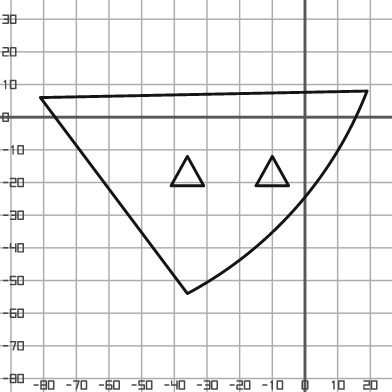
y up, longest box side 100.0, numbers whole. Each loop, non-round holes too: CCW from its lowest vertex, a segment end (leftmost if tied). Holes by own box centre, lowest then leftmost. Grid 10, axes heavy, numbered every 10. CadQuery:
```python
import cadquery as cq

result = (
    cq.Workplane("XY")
    .moveTo(-36.0, -54.0)
    .threePointArc((-3.0, -28.0), (19.0, 8.0))
    .lineTo(-81.0, 6.0)
    .close()
    .moveTo(-41.0, -21.0)
    .lineTo(-31.0, -21.0)
    .lineTo(-36.0, -12.0)
    .close()
    .moveTo(-15.0, -21.0)
    .lineTo(-5.0, -21.0)
    .lineTo(-10.0, -12.0)
    .close()
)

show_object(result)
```